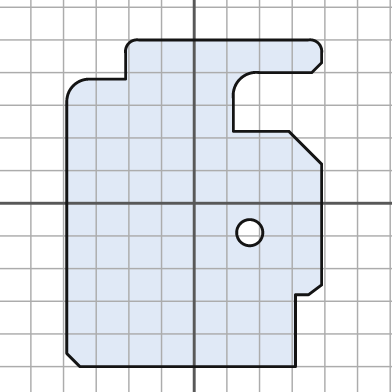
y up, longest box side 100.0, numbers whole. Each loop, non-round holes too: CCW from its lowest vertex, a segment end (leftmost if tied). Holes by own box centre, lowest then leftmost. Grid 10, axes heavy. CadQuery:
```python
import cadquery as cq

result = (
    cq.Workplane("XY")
    .moveTo(-35.0, -50.0)
    .lineTo(31.0, -50.0)
    .lineTo(31.0, -28.0)
    .lineTo(35.0, -28.0)
    .lineTo(39.0, -25.0)
    .lineTo(39.0, 12.0)
    .lineTo(29.0, 22.0)
    .lineTo(12.0, 22.0)
    .lineTo(12.0, 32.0)
    .threePointArc((14.0, 38.0), (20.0, 40.0))
    .lineTo(36.0, 40.0)
    .lineTo(39.0, 43.0)
    .lineTo(39.0, 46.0)
    .threePointArc((38.0, 49.0), (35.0, 50.0))
    .lineTo(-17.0, 50.0)
    .threePointArc((-20.0, 49.0), (-21.0, 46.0))
    .lineTo(-21.0, 38.0)
    .lineTo(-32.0, 38.0)
    .threePointArc((-37.0, 36.0), (-39.0, 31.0))
    .lineTo(-39.0, -46.0)
    .close()
    .moveTo(17.0, -9.0)
    .circle(4.0)
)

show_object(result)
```